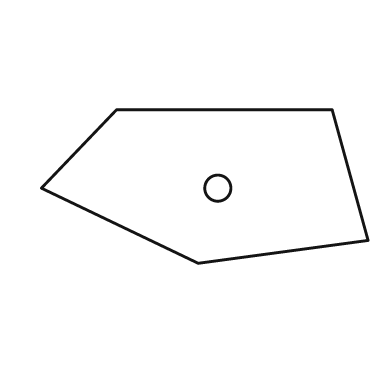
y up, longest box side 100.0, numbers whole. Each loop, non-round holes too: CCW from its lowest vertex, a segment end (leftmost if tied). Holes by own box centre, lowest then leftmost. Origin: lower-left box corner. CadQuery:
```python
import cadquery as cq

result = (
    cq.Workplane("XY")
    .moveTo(48.0, 0.0)
    .lineTo(100.0, 7.0)
    .lineTo(89.0, 47.0)
    .lineTo(23.0, 47.0)
    .lineTo(0.0, 23.0)
    .close()
    .moveTo(54.0, 23.0)
    .circle(4.0)
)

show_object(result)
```